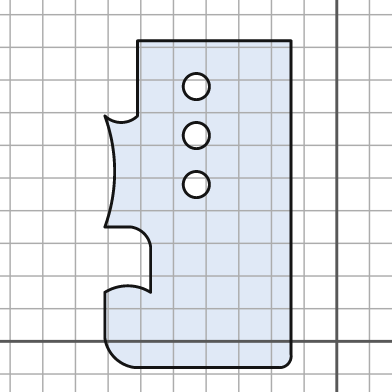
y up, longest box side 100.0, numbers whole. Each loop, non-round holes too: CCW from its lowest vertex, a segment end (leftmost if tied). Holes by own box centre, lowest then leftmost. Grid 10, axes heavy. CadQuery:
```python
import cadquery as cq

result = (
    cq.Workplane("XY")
    .moveTo(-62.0, -8.0)
    .lineTo(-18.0, -8.0)
    .threePointArc((-15.0, -7.0), (-14.0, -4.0))
    .lineTo(-14.0, 92.0)
    .lineTo(-61.0, 92.0)
    .lineTo(-61.0, 69.0)
    .threePointArc((-66.0, 67.0), (-71.0, 69.0))
    .threePointArc((-68.0, 52.0), (-71.0, 35.0))
    .lineTo(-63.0, 35.0)
    .threePointArc((-59.0, 33.0), (-57.0, 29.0))
    .lineTo(-57.0, 15.0)
    .threePointArc((-64.0, 17.0), (-71.0, 15.0))
    .lineTo(-71.0, 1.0)
    .threePointArc((-68.0, -5.0), (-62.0, -8.0))
    .close()
    .moveTo(-43.0, 48.0)
    .circle(4.0)
    .moveTo(-43.0, 63.0)
    .circle(4.0)
    .moveTo(-43.0, 78.0)
    .circle(4.0)
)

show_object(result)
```